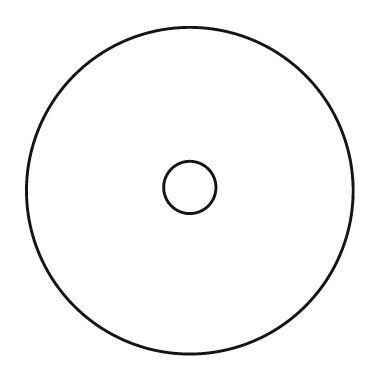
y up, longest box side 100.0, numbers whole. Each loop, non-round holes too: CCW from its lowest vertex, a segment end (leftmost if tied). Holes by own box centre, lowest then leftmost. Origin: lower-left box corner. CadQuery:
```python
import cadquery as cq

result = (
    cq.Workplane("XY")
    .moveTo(50.0, 50.0)
    .circle(50.0)
    .moveTo(50.0, 51.0)
    .circle(8.0)
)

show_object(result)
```